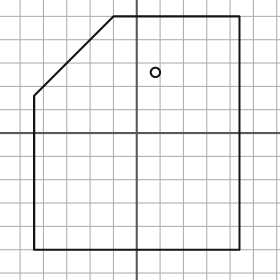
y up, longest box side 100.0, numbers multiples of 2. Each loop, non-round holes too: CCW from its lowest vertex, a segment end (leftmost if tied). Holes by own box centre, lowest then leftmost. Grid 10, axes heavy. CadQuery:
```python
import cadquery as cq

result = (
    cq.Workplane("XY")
    .moveTo(-44.0, -50.0)
    .lineTo(44.0, -50.0)
    .lineTo(44.0, 50.0)
    .lineTo(-10.0, 50.0)
    .lineTo(-44.0, 16.0)
    .close()
    .moveTo(8.0, 26.0)
    .circle(2.0)
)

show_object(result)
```